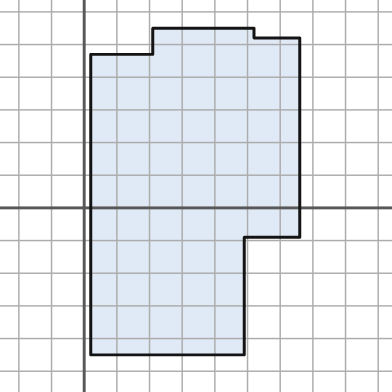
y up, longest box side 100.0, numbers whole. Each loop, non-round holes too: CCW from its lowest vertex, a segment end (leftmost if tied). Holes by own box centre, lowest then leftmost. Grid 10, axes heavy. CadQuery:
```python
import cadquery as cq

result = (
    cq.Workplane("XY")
    .moveTo(2.0, -45.0)
    .lineTo(49.0, -45.0)
    .lineTo(49.0, -9.0)
    .lineTo(66.0, -9.0)
    .lineTo(66.0, 52.0)
    .lineTo(52.0, 52.0)
    .lineTo(52.0, 55.0)
    .lineTo(21.0, 55.0)
    .lineTo(21.0, 47.0)
    .lineTo(2.0, 47.0)
    .close()
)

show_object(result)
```